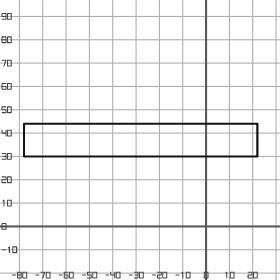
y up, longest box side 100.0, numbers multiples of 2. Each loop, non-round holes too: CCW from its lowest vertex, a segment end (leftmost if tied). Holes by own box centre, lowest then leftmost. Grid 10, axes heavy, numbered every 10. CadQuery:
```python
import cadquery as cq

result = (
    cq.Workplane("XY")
    .moveTo(-78.0, 30.0)
    .lineTo(22.0, 30.0)
    .lineTo(22.0, 44.0)
    .lineTo(-78.0, 44.0)
    .close()
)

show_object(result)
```